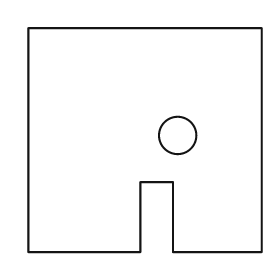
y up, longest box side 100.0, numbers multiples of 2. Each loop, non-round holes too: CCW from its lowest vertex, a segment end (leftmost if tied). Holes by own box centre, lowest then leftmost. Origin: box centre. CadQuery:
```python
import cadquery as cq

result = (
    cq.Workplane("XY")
    .moveTo(-50.0, -48.0)
    .lineTo(-2.0, -48.0)
    .lineTo(-2.0, -18.0)
    .lineTo(12.0, -18.0)
    .lineTo(12.0, -48.0)
    .lineTo(50.0, -48.0)
    .lineTo(50.0, 48.0)
    .lineTo(-50.0, 48.0)
    .close()
    .moveTo(14.0, 2.0)
    .circle(8.0)
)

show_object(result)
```